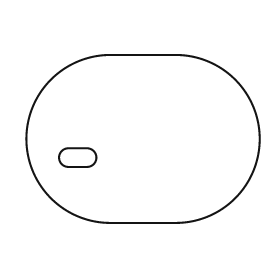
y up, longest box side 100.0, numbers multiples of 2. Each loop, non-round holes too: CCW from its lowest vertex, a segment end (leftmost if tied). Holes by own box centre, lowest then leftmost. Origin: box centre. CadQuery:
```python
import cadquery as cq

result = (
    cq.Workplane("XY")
    .moveTo(-14.0, -36.0)
    .lineTo(14.0, -36.0)
    .threePointArc((50.0, 0.0), (14.0, 36.0))
    .lineTo(-14.0, 36.0)
    .threePointArc((-50.0, 0.0), (-14.0, -36.0))
    .close()
    .moveTo(-32.0, -12.0)
    .lineTo(-24.0, -12.0)
    .threePointArc((-20.0, -8.0), (-24.0, -4.0))
    .lineTo(-32.0, -4.0)
    .threePointArc((-36.0, -8.0), (-32.0, -12.0))
    .close()
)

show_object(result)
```